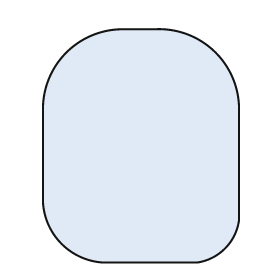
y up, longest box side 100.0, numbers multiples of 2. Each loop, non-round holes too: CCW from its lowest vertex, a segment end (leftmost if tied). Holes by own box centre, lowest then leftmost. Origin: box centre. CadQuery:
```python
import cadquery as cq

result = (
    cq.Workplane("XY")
    .moveTo(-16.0, -50.0)
    .lineTo(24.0, -50.0)
    .threePointArc((36.0, -44.0), (42.0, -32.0))
    .lineTo(42.0, 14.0)
    .threePointArc((32.0, 40.0), (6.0, 50.0))
    .lineTo(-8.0, 50.0)
    .threePointArc((-32.0, 40.0), (-42.0, 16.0))
    .lineTo(-42.0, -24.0)
    .threePointArc((-34.0, -42.0), (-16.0, -50.0))
    .close()
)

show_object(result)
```